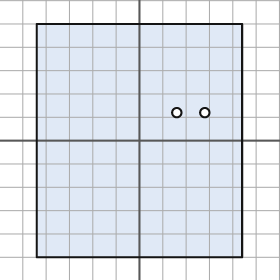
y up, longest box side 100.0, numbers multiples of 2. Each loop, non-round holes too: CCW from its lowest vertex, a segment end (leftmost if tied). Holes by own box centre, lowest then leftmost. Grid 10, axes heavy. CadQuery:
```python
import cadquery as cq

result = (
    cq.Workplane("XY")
    .moveTo(-44.0, -50.0)
    .lineTo(44.0, -50.0)
    .lineTo(44.0, 50.0)
    .lineTo(-44.0, 50.0)
    .close()
    .moveTo(16.0, 12.0)
    .circle(2.0)
    .moveTo(28.0, 12.0)
    .circle(2.0)
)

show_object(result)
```